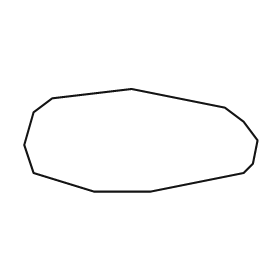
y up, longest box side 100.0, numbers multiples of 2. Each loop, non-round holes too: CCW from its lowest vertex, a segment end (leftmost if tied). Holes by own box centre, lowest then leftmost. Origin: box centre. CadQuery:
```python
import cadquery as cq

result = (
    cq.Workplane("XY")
    .moveTo(-20.0, -22.0)
    .lineTo(4.0, -22.0)
    .lineTo(44.0, -14.0)
    .lineTo(48.0, -10.0)
    .lineTo(50.0, 0.0)
    .lineTo(44.0, 8.0)
    .lineTo(36.0, 14.0)
    .lineTo(-4.0, 22.0)
    .lineTo(-38.0, 18.0)
    .lineTo(-46.0, 12.0)
    .lineTo(-50.0, -2.0)
    .lineTo(-46.0, -14.0)
    .close()
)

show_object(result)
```